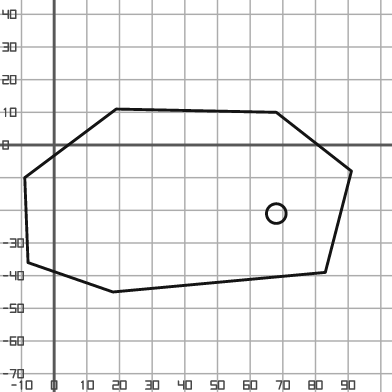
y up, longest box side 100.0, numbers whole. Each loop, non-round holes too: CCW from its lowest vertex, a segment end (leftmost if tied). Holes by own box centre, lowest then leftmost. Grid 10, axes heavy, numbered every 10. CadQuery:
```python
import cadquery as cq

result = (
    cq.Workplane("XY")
    .moveTo(18.0, -45.0)
    .lineTo(83.0, -39.0)
    .lineTo(91.0, -8.0)
    .lineTo(68.0, 10.0)
    .lineTo(19.0, 11.0)
    .lineTo(-9.0, -10.0)
    .lineTo(-8.0, -36.0)
    .close()
    .moveTo(68.0, -21.0)
    .circle(3.0)
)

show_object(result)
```